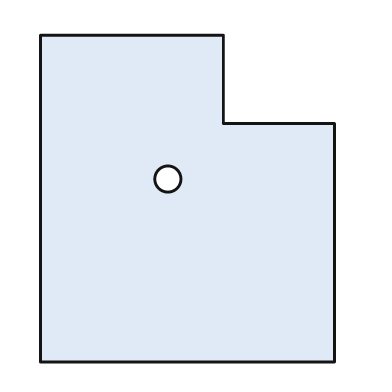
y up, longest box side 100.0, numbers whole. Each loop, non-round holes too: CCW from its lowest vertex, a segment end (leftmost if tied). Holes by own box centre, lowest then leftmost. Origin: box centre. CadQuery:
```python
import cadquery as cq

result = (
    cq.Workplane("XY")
    .moveTo(-45.0, -50.0)
    .lineTo(45.0, -50.0)
    .lineTo(45.0, 23.0)
    .lineTo(11.0, 23.0)
    .lineTo(11.0, 50.0)
    .lineTo(-45.0, 50.0)
    .close()
    .moveTo(-6.0, 6.0)
    .circle(4.0)
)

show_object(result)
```